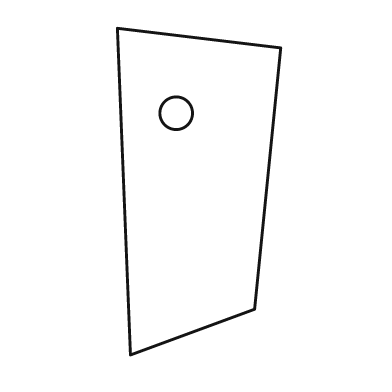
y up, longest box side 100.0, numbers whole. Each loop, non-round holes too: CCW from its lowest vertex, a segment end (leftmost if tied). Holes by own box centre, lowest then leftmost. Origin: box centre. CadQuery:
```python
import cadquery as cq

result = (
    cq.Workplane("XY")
    .moveTo(-21.0, -50.0)
    .lineTo(17.0, -36.0)
    .lineTo(25.0, 44.0)
    .lineTo(-25.0, 50.0)
    .close()
    .moveTo(-7.0, 24.0)
    .circle(5.0)
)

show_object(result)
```